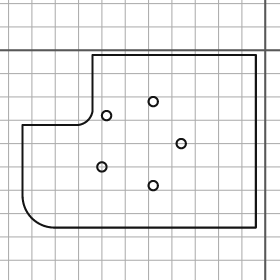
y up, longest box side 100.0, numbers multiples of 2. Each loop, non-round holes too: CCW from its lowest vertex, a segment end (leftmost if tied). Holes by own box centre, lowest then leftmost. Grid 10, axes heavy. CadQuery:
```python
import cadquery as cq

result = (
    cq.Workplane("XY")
    .moveTo(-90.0, -76.0)
    .lineTo(-4.0, -76.0)
    .lineTo(-4.0, -2.0)
    .lineTo(-74.0, -2.0)
    .lineTo(-74.0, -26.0)
    .threePointArc((-76.0, -30.0), (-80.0, -32.0))
    .lineTo(-104.0, -32.0)
    .lineTo(-104.0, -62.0)
    .threePointArc((-100.0, -72.0), (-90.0, -76.0))
    .close()
    .moveTo(-48.0, -58.0)
    .circle(2.0)
    .moveTo(-70.0, -50.0)
    .circle(2.0)
    .moveTo(-36.0, -40.0)
    .circle(2.0)
    .moveTo(-68.0, -28.0)
    .circle(2.0)
    .moveTo(-48.0, -22.0)
    .circle(2.0)
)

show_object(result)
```